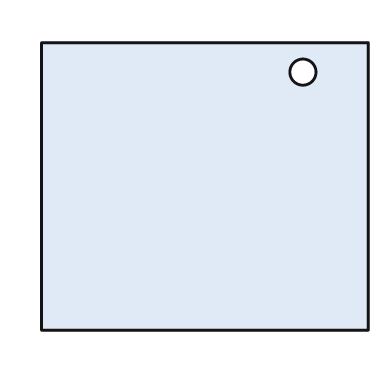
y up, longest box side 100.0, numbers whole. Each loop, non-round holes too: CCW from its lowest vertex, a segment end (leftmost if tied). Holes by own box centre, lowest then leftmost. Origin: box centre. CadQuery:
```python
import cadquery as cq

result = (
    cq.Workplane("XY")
    .moveTo(-50.0, -44.0)
    .lineTo(50.0, -44.0)
    .lineTo(50.0, 44.0)
    .lineTo(-50.0, 44.0)
    .close()
    .moveTo(30.0, 35.0)
    .circle(4.0)
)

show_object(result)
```